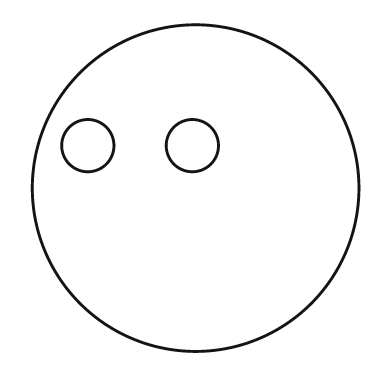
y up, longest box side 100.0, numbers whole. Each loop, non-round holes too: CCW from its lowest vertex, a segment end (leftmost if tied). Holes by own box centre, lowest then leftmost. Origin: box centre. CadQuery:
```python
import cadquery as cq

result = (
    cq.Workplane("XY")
    .moveTo(0.0, 0.0)
    .circle(50.0)
    .moveTo(-33.0, 13.0)
    .circle(8.0)
    .moveTo(-1.0, 13.0)
    .circle(8.0)
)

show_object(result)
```